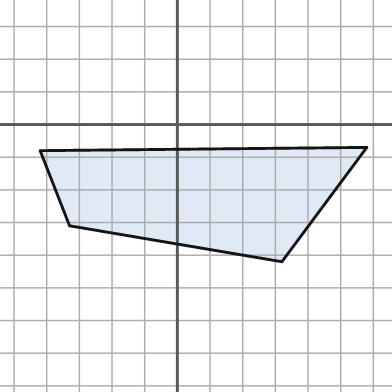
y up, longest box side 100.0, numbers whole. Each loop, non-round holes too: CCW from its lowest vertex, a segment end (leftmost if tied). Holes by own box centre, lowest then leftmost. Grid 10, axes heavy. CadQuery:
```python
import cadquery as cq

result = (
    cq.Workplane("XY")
    .moveTo(32.0, -42.0)
    .lineTo(58.0, -7.0)
    .lineTo(-42.0, -8.0)
    .lineTo(-33.0, -31.0)
    .close()
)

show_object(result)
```